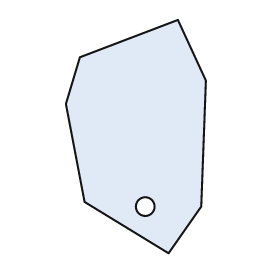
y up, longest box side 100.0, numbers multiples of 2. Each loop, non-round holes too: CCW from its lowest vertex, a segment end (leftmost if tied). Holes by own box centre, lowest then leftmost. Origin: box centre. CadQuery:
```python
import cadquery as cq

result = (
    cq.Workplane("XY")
    .moveTo(14.0, -50.0)
    .lineTo(28.0, -30.0)
    .lineTo(30.0, 24.0)
    .lineTo(18.0, 50.0)
    .lineTo(-24.0, 34.0)
    .lineTo(-30.0, 14.0)
    .lineTo(-22.0, -28.0)
    .close()
    .moveTo(4.0, -30.0)
    .circle(4.0)
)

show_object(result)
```